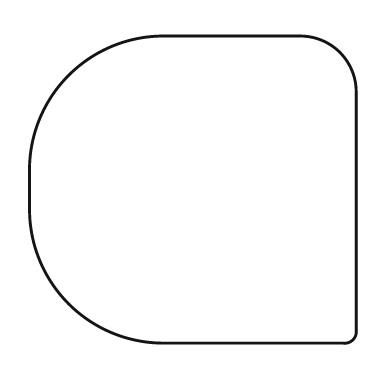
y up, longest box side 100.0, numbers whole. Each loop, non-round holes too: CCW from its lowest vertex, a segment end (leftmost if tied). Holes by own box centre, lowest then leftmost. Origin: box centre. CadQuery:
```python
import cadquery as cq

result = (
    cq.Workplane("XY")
    .moveTo(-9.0, -47.0)
    .lineTo(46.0, -47.0)
    .threePointArc((49.0, -46.0), (50.0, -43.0))
    .lineTo(50.0, 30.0)
    .threePointArc((45.0, 42.0), (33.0, 47.0))
    .lineTo(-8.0, 47.0)
    .threePointArc((-38.0, 35.0), (-50.0, 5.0))
    .lineTo(-50.0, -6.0)
    .threePointArc((-38.0, -35.0), (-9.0, -47.0))
    .close()
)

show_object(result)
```